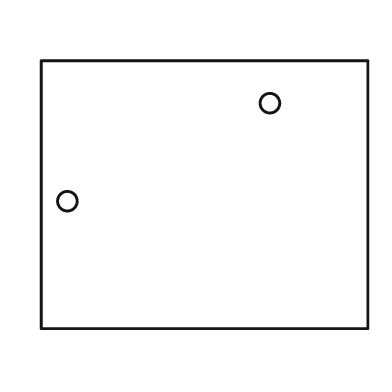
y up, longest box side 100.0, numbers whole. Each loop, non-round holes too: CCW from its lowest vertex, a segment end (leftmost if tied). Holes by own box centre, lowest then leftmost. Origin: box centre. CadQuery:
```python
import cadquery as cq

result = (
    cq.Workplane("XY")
    .moveTo(-50.0, -41.0)
    .lineTo(50.0, -41.0)
    .lineTo(50.0, 41.0)
    .lineTo(-50.0, 41.0)
    .close()
    .moveTo(-42.0, -2.0)
    .circle(3.0)
    .moveTo(20.0, 28.0)
    .circle(3.0)
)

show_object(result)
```